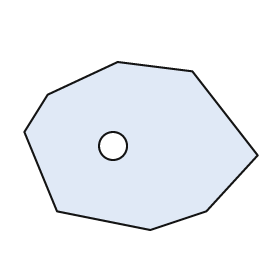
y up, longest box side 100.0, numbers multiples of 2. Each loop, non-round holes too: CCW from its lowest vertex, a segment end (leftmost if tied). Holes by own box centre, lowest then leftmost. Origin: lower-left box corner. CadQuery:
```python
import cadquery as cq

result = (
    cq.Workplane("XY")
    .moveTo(54.0, 0.0)
    .lineTo(78.0, 8.0)
    .lineTo(100.0, 32.0)
    .lineTo(72.0, 68.0)
    .lineTo(40.0, 72.0)
    .lineTo(10.0, 58.0)
    .lineTo(0.0, 42.0)
    .lineTo(14.0, 8.0)
    .close()
    .moveTo(38.0, 36.0)
    .circle(6.0)
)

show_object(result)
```